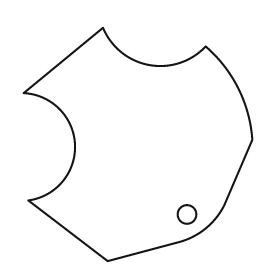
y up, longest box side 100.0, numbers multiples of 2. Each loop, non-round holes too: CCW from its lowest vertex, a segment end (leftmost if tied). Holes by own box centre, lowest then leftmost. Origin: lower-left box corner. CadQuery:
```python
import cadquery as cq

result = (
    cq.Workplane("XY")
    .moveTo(36.0, 0.0)
    .lineTo(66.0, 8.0)
    .threePointArc((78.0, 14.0), (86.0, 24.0))
    .lineTo(98.0, 52.0)
    .threePointArc((92.0, 74.0), (78.0, 92.0))
    .threePointArc((54.0, 84.0), (34.0, 100.0))
    .lineTo(0.0, 72.0)
    .threePointArc((22.0, 50.0), (2.0, 26.0))
    .close()
    .moveTo(70.0, 20.0)
    .circle(4.0)
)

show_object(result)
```